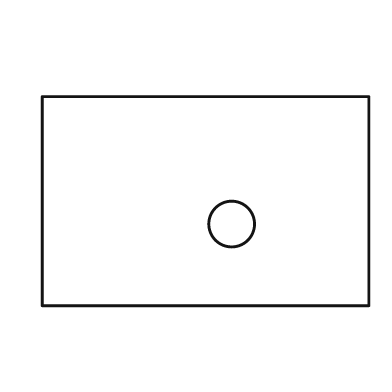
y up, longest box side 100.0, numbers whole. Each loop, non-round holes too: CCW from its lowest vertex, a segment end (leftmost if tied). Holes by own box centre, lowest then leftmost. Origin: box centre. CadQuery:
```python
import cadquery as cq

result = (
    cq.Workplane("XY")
    .moveTo(-50.0, -32.0)
    .lineTo(50.0, -32.0)
    .lineTo(50.0, 32.0)
    .lineTo(-50.0, 32.0)
    .close()
    .moveTo(8.0, -7.0)
    .circle(7.0)
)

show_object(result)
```